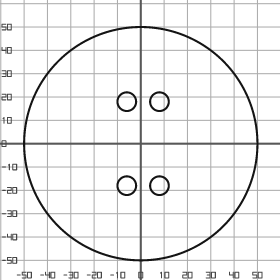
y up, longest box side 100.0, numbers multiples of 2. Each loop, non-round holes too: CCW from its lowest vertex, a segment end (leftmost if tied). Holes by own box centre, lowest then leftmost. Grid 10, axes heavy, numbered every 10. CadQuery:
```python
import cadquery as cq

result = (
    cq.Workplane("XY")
    .moveTo(0.0, 0.0)
    .circle(50.0)
    .moveTo(-6.0, -18.0)
    .circle(4.0)
    .moveTo(8.0, -18.0)
    .circle(4.0)
    .moveTo(-6.0, 18.0)
    .circle(4.0)
    .moveTo(8.0, 18.0)
    .circle(4.0)
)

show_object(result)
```